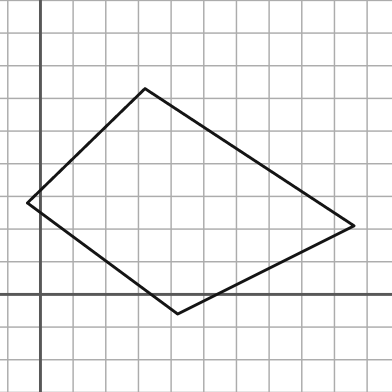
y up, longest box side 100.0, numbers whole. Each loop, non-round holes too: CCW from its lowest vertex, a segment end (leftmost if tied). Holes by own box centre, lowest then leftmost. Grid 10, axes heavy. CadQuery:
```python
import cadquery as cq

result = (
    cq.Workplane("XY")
    .moveTo(42.0, -6.0)
    .lineTo(96.0, 21.0)
    .lineTo(32.0, 63.0)
    .lineTo(-4.0, 28.0)
    .close()
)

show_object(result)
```